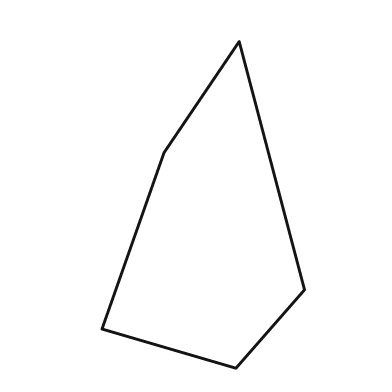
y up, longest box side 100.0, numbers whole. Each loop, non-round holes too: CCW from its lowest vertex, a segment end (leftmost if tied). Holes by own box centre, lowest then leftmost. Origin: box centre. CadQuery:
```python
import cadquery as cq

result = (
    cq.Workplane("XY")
    .moveTo(10.0, -50.0)
    .lineTo(31.0, -26.0)
    .lineTo(11.0, 50.0)
    .lineTo(-12.0, 16.0)
    .lineTo(-31.0, -38.0)
    .close()
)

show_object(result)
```